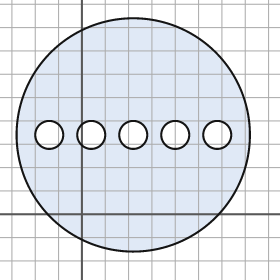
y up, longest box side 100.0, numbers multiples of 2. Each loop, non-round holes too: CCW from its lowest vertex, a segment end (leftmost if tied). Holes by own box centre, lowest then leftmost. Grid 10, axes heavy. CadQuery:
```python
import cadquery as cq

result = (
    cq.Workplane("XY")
    .moveTo(22.0, 34.0)
    .circle(50.0)
    .moveTo(-14.0, 34.0)
    .circle(6.0)
    .moveTo(4.0, 34.0)
    .circle(6.0)
    .moveTo(22.0, 34.0)
    .circle(6.0)
    .moveTo(40.0, 34.0)
    .circle(6.0)
    .moveTo(58.0, 34.0)
    .circle(6.0)
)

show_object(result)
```